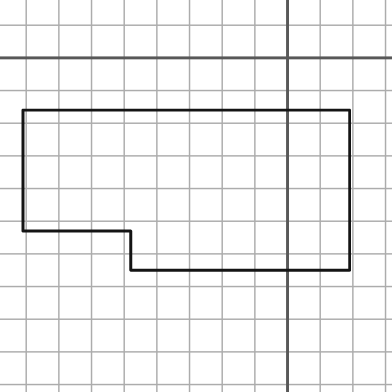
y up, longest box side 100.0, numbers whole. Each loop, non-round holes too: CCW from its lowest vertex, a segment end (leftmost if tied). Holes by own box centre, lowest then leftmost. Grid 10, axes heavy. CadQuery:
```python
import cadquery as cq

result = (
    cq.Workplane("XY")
    .moveTo(-48.0, -65.0)
    .lineTo(19.0, -65.0)
    .lineTo(19.0, -16.0)
    .lineTo(-81.0, -16.0)
    .lineTo(-81.0, -53.0)
    .lineTo(-48.0, -53.0)
    .close()
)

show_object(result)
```